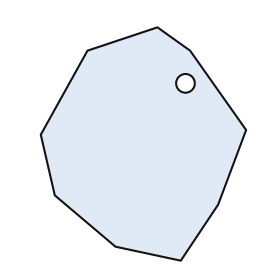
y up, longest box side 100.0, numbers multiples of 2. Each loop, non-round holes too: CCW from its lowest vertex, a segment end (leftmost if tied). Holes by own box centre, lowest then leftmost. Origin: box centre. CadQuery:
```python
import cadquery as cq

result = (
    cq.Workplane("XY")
    .moveTo(16.0, -50.0)
    .lineTo(32.0, -26.0)
    .lineTo(44.0, 6.0)
    .lineTo(20.0, 40.0)
    .lineTo(6.0, 50.0)
    .lineTo(-24.0, 40.0)
    .lineTo(-44.0, 4.0)
    .lineTo(-38.0, -22.0)
    .lineTo(-12.0, -44.0)
    .close()
    .moveTo(18.0, 26.0)
    .circle(4.0)
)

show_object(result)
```